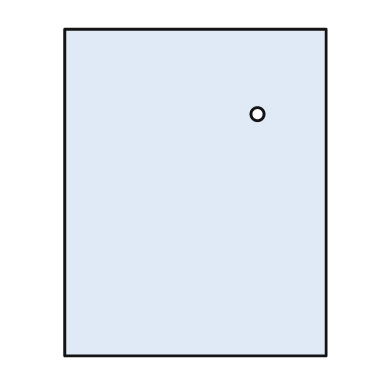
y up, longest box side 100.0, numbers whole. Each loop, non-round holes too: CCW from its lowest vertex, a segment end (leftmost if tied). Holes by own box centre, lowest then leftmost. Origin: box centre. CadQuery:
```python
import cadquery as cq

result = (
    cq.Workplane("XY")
    .moveTo(-40.0, -50.0)
    .lineTo(40.0, -50.0)
    .lineTo(40.0, 50.0)
    .lineTo(-40.0, 50.0)
    .close()
    .moveTo(19.0, 24.0)
    .circle(2.0)
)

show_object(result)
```